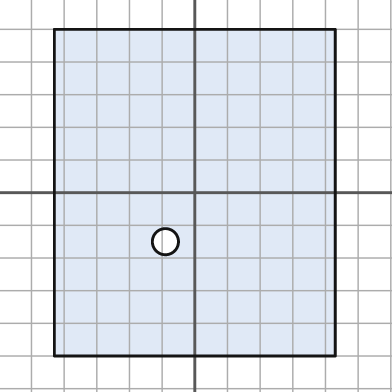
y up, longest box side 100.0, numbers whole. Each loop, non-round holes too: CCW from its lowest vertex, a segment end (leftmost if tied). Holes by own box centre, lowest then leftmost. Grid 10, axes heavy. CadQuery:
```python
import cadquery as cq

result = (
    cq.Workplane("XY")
    .moveTo(-43.0, -50.0)
    .lineTo(43.0, -50.0)
    .lineTo(43.0, 50.0)
    .lineTo(-43.0, 50.0)
    .close()
    .moveTo(-9.0, -15.0)
    .circle(4.0)
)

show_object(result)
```